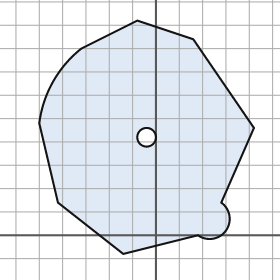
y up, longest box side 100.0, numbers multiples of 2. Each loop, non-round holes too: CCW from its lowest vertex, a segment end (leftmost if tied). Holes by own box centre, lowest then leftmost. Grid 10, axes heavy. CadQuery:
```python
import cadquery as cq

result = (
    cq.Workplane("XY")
    .moveTo(-14.0, -8.0)
    .lineTo(18.0, 0.0)
    .threePointArc((30.0, 2.0), (28.0, 14.0))
    .lineTo(42.0, 46.0)
    .lineTo(16.0, 84.0)
    .lineTo(-8.0, 92.0)
    .lineTo(-32.0, 80.0)
    .threePointArc((-44.0, 66.0), (-50.0, 48.0))
    .lineTo(-42.0, 14.0)
    .close()
    .moveTo(-4.0, 42.0)
    .circle(4.0)
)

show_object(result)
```